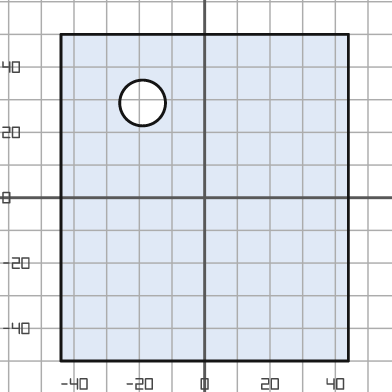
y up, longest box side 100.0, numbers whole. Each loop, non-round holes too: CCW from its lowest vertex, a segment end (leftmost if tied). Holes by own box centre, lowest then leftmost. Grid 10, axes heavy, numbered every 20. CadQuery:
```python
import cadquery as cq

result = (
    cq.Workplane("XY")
    .moveTo(-44.0, -50.0)
    .lineTo(44.0, -50.0)
    .lineTo(44.0, 50.0)
    .lineTo(-44.0, 50.0)
    .close()
    .moveTo(-19.0, 29.0)
    .circle(7.0)
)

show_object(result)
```